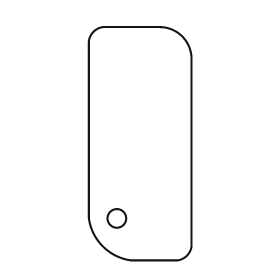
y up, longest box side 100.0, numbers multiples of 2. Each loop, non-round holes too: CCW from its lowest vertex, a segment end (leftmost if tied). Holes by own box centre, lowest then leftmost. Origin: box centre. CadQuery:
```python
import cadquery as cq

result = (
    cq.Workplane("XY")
    .moveTo(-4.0, -50.0)
    .lineTo(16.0, -50.0)
    .threePointArc((20.0, -48.0), (22.0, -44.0))
    .lineTo(22.0, 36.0)
    .threePointArc((18.0, 46.0), (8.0, 50.0))
    .lineTo(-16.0, 50.0)
    .threePointArc((-20.0, 48.0), (-22.0, 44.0))
    .lineTo(-22.0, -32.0)
    .threePointArc((-16.0, -44.0), (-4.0, -50.0))
    .close()
    .moveTo(-10.0, -32.0)
    .circle(4.0)
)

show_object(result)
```